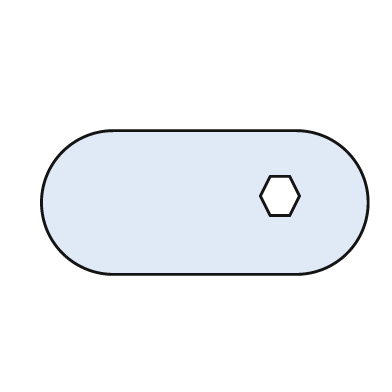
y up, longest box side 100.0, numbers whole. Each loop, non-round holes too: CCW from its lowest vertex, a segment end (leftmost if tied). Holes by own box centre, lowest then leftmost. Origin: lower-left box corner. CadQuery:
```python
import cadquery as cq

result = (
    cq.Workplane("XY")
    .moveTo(22.0, 0.0)
    .lineTo(78.0, 0.0)
    .threePointArc((100.0, 22.0), (78.0, 44.0))
    .lineTo(22.0, 44.0)
    .threePointArc((0.0, 22.0), (22.0, 0.0))
    .close()
    .moveTo(70.0, 18.0)
    .lineTo(76.0, 18.0)
    .lineTo(79.0, 24.0)
    .lineTo(76.0, 30.0)
    .lineTo(70.0, 30.0)
    .lineTo(67.0, 24.0)
    .close()
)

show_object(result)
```